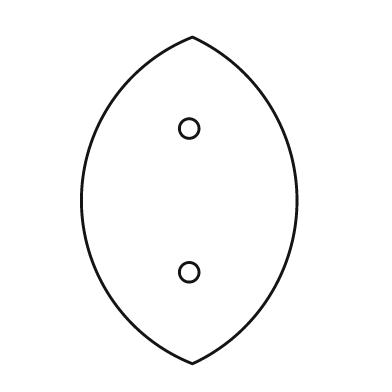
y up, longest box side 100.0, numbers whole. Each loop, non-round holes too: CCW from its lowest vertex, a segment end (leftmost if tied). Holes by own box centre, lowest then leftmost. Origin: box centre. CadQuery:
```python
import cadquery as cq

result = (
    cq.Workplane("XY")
    .moveTo(1.0, -50.0)
    .threePointArc((33.0, 0.0), (1.0, 50.0))
    .threePointArc((-33.0, 0.0), (1.0, -50.0))
    .close()
    .moveTo(0.0, -22.0)
    .circle(3.0)
    .moveTo(0.0, 22.0)
    .circle(3.0)
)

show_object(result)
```